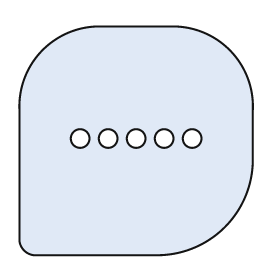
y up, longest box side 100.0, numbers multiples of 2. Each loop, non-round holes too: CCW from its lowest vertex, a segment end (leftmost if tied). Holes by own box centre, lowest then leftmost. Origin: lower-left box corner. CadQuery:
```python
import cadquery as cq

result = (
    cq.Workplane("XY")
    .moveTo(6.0, 0.0)
    .lineTo(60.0, 0.0)
    .threePointArc((88.0, 12.0), (100.0, 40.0))
    .lineTo(100.0, 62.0)
    .threePointArc((90.0, 88.0), (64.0, 98.0))
    .lineTo(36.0, 98.0)
    .threePointArc((10.0, 88.0), (0.0, 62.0))
    .lineTo(0.0, 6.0)
    .threePointArc((2.0, 2.0), (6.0, 0.0))
    .close()
    .moveTo(26.0, 50.0)
    .circle(4.0)
    .moveTo(38.0, 50.0)
    .circle(4.0)
    .moveTo(50.0, 50.0)
    .circle(4.0)
    .moveTo(62.0, 50.0)
    .circle(4.0)
    .moveTo(74.0, 50.0)
    .circle(4.0)
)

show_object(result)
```